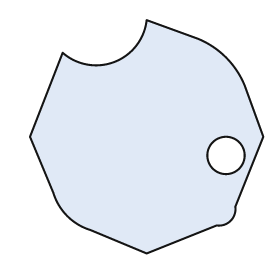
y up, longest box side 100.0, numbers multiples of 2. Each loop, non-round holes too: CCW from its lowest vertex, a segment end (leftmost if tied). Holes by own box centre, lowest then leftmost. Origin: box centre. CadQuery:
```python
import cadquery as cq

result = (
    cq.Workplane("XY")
    .moveTo(0.0, -50.0)
    .lineTo(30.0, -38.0)
    .threePointArc((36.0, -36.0), (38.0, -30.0))
    .lineTo(50.0, 0.0)
    .lineTo(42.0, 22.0)
    .threePointArc((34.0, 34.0), (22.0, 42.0))
    .lineTo(0.0, 50.0)
    .threePointArc((-14.0, 32.0), (-36.0, 36.0))
    .lineTo(-50.0, 0.0)
    .lineTo(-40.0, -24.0)
    .threePointArc((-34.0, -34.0), (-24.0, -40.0))
    .close()
    .moveTo(34.0, -8.0)
    .circle(8.0)
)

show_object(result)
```